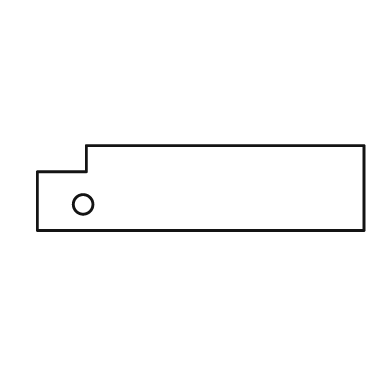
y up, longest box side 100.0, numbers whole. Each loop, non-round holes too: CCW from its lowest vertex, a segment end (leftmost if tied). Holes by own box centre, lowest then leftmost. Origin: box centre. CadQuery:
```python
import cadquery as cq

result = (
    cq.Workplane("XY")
    .moveTo(-50.0, -13.0)
    .lineTo(50.0, -13.0)
    .lineTo(50.0, 13.0)
    .lineTo(-35.0, 13.0)
    .lineTo(-35.0, 5.0)
    .lineTo(-50.0, 5.0)
    .close()
    .moveTo(-36.0, -5.0)
    .circle(3.0)
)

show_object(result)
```